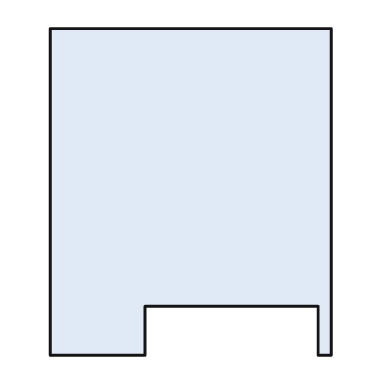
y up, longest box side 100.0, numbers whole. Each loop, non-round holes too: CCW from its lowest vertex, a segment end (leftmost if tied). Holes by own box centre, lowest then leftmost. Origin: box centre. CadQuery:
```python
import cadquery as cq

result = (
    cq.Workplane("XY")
    .moveTo(-43.0, -50.0)
    .lineTo(-14.0, -50.0)
    .lineTo(-14.0, -35.0)
    .lineTo(39.0, -35.0)
    .lineTo(39.0, -50.0)
    .lineTo(43.0, -50.0)
    .lineTo(43.0, 50.0)
    .lineTo(-43.0, 50.0)
    .close()
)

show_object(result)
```